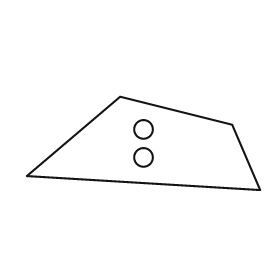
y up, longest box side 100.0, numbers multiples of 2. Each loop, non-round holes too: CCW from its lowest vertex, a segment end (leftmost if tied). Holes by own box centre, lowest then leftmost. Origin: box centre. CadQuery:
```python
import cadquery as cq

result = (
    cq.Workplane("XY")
    .moveTo(50.0, -20.0)
    .lineTo(38.0, 8.0)
    .lineTo(-10.0, 20.0)
    .lineTo(-50.0, -14.0)
    .close()
    .moveTo(0.0, -6.0)
    .circle(4.0)
    .moveTo(0.0, 6.0)
    .circle(4.0)
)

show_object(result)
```